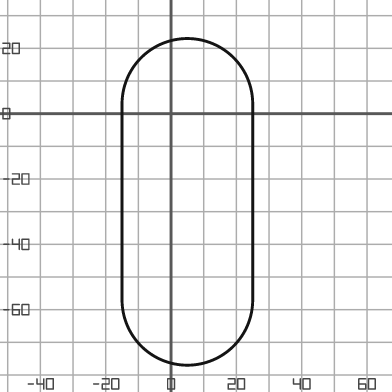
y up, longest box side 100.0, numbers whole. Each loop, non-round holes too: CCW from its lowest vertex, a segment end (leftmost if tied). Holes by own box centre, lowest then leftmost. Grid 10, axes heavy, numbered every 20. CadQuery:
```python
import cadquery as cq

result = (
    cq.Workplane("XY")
    .moveTo(-15.0, -57.0)
    .threePointArc((5.0, -77.0), (25.0, -57.0))
    .lineTo(25.0, 3.0)
    .threePointArc((5.0, 23.0), (-15.0, 3.0))
    .close()
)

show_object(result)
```